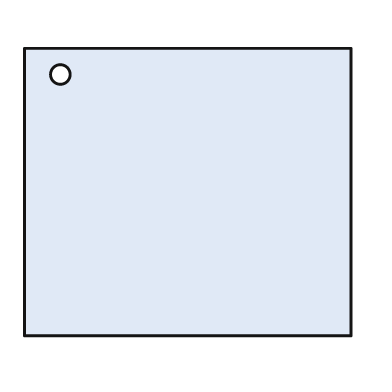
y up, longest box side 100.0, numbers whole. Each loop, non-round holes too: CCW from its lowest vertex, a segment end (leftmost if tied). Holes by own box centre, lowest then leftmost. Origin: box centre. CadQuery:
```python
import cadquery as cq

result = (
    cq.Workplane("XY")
    .moveTo(-50.0, -44.0)
    .lineTo(50.0, -44.0)
    .lineTo(50.0, 44.0)
    .lineTo(-50.0, 44.0)
    .close()
    .moveTo(-39.0, 36.0)
    .circle(3.0)
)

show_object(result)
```